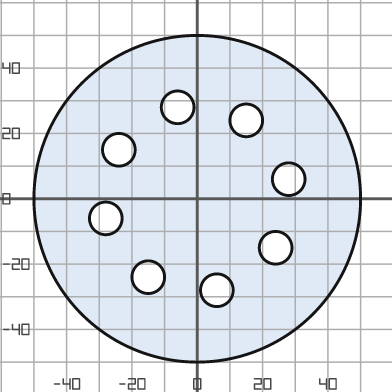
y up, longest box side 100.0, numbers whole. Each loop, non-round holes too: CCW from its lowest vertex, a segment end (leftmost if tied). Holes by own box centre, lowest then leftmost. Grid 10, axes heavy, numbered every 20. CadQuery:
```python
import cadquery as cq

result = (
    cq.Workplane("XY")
    .moveTo(0.0, 0.0)
    .circle(50.0)
    .moveTo(6.0, -28.0)
    .circle(5.0)
    .moveTo(-15.0, -24.0)
    .circle(5.0)
    .moveTo(24.0, -15.0)
    .circle(5.0)
    .moveTo(-28.0, -6.0)
    .circle(5.0)
    .moveTo(28.0, 6.0)
    .circle(5.0)
    .moveTo(-24.0, 15.0)
    .circle(5.0)
    .moveTo(15.0, 24.0)
    .circle(5.0)
    .moveTo(-6.0, 28.0)
    .circle(5.0)
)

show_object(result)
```